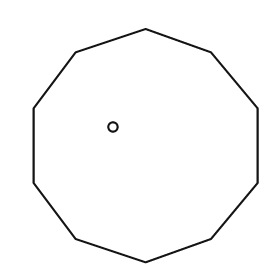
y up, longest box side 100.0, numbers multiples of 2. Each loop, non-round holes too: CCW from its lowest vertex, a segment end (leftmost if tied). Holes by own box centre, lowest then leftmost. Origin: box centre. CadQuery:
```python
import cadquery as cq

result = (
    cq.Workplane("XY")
    .moveTo(0.0, -50.0)
    .lineTo(28.0, -40.0)
    .lineTo(48.0, -16.0)
    .lineTo(48.0, 16.0)
    .lineTo(28.0, 40.0)
    .lineTo(0.0, 50.0)
    .lineTo(-30.0, 40.0)
    .lineTo(-48.0, 16.0)
    .lineTo(-48.0, -16.0)
    .lineTo(-30.0, -40.0)
    .close()
    .moveTo(-14.0, 8.0)
    .circle(2.0)
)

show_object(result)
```